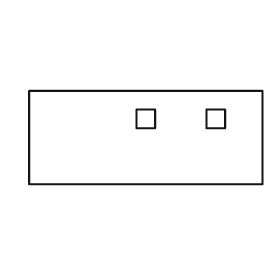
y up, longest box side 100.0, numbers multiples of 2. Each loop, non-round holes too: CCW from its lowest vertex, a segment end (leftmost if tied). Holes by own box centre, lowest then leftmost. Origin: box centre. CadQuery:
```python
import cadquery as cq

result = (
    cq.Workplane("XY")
    .moveTo(-50.0, -20.0)
    .lineTo(50.0, -20.0)
    .lineTo(50.0, 20.0)
    .lineTo(-50.0, 20.0)
    .close()
    .moveTo(-4.0, 4.0)
    .lineTo(4.0, 4.0)
    .lineTo(4.0, 12.0)
    .lineTo(-4.0, 12.0)
    .close()
    .moveTo(26.0, 4.0)
    .lineTo(34.0, 4.0)
    .lineTo(34.0, 12.0)
    .lineTo(26.0, 12.0)
    .close()
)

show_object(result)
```